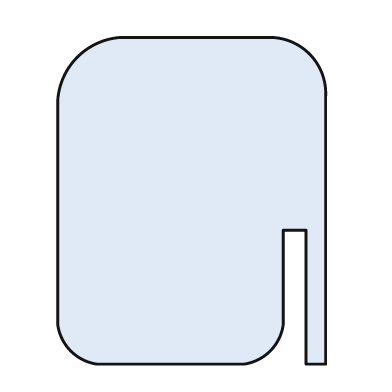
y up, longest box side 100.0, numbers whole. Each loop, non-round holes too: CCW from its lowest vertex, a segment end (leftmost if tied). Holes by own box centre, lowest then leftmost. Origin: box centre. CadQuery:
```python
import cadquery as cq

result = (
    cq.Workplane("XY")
    .moveTo(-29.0, -50.0)
    .lineTo(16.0, -50.0)
    .threePointArc((24.0, -46.0), (28.0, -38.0))
    .lineTo(28.0, -9.0)
    .lineTo(35.0, -9.0)
    .lineTo(35.0, -50.0)
    .lineTo(41.0, -50.0)
    .lineTo(41.0, 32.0)
    .threePointArc((36.0, 45.0), (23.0, 50.0))
    .lineTo(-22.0, 50.0)
    .threePointArc((-35.0, 44.0), (-41.0, 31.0))
    .lineTo(-41.0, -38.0)
    .threePointArc((-37.0, -46.0), (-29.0, -50.0))
    .close()
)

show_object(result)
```